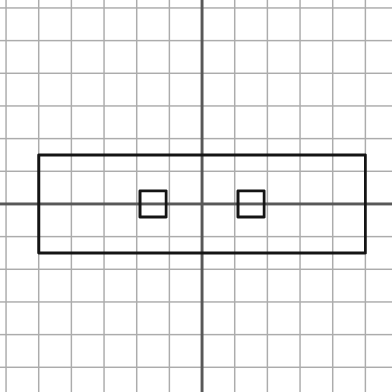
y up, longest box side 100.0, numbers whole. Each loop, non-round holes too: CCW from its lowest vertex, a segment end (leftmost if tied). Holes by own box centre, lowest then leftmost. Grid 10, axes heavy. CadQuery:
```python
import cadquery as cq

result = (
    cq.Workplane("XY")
    .moveTo(-50.0, -15.0)
    .lineTo(50.0, -15.0)
    .lineTo(50.0, 15.0)
    .lineTo(-50.0, 15.0)
    .close()
    .moveTo(-19.0, -4.0)
    .lineTo(-11.0, -4.0)
    .lineTo(-11.0, 4.0)
    .lineTo(-19.0, 4.0)
    .close()
    .moveTo(11.0, -4.0)
    .lineTo(19.0, -4.0)
    .lineTo(19.0, 4.0)
    .lineTo(11.0, 4.0)
    .close()
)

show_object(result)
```